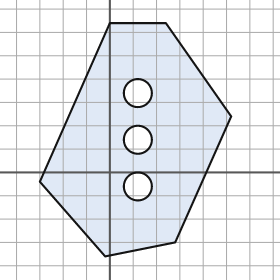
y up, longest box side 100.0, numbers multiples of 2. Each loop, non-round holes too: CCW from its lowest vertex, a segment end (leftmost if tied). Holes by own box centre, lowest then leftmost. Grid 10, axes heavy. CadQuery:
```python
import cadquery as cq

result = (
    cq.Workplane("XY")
    .moveTo(-2.0, -36.0)
    .lineTo(28.0, -30.0)
    .lineTo(52.0, 24.0)
    .lineTo(24.0, 64.0)
    .lineTo(0.0, 64.0)
    .lineTo(-30.0, -4.0)
    .close()
    .moveTo(12.0, -6.0)
    .circle(6.0)
    .moveTo(12.0, 14.0)
    .circle(6.0)
    .moveTo(12.0, 34.0)
    .circle(6.0)
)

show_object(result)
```